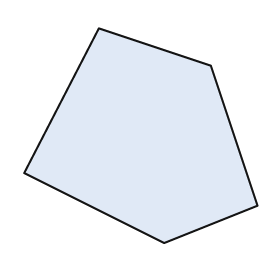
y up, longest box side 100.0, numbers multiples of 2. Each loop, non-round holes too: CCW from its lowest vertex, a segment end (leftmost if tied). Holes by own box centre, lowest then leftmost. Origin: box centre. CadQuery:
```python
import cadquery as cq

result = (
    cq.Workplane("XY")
    .moveTo(10.0, -46.0)
    .lineTo(50.0, -30.0)
    .lineTo(30.0, 30.0)
    .lineTo(-18.0, 46.0)
    .lineTo(-50.0, -16.0)
    .close()
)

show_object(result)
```